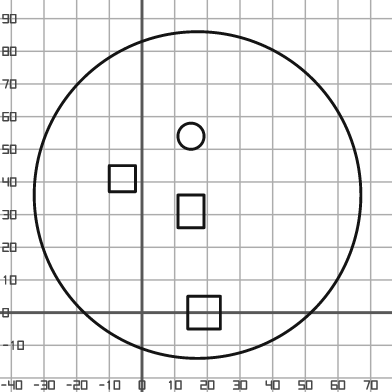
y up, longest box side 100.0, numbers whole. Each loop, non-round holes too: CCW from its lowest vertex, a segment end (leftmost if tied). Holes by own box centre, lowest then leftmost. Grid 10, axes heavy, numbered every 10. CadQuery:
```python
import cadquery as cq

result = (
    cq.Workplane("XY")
    .moveTo(17.0, 36.0)
    .circle(50.0)
    .moveTo(14.0, -5.0)
    .lineTo(24.0, -5.0)
    .lineTo(24.0, 5.0)
    .lineTo(14.0, 5.0)
    .close()
    .moveTo(11.0, 26.0)
    .lineTo(19.0, 26.0)
    .lineTo(19.0, 36.0)
    .lineTo(11.0, 36.0)
    .close()
    .moveTo(-10.0, 37.0)
    .lineTo(-2.0, 37.0)
    .lineTo(-2.0, 45.0)
    .lineTo(-10.0, 45.0)
    .close()
    .moveTo(15.0, 54.0)
    .circle(4.0)
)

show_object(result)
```